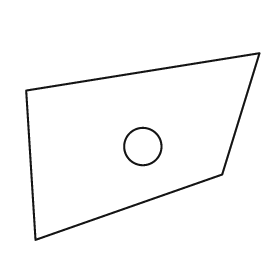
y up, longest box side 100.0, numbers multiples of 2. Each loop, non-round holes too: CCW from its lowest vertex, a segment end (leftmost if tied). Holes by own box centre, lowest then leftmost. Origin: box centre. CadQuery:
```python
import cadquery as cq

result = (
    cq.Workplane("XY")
    .moveTo(-46.0, -40.0)
    .lineTo(34.0, -12.0)
    .lineTo(50.0, 40.0)
    .lineTo(-50.0, 24.0)
    .close()
    .moveTo(0.0, 0.0)
    .circle(8.0)
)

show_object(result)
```